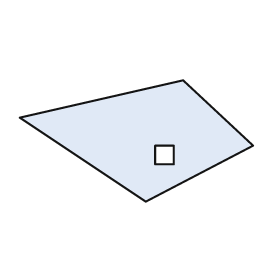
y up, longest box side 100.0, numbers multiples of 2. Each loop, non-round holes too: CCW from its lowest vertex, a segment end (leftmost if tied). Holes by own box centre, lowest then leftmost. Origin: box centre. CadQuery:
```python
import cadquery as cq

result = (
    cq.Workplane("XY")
    .moveTo(4.0, -26.0)
    .lineTo(50.0, -2.0)
    .lineTo(20.0, 26.0)
    .lineTo(-50.0, 10.0)
    .close()
    .moveTo(8.0, -10.0)
    .lineTo(16.0, -10.0)
    .lineTo(16.0, -2.0)
    .lineTo(8.0, -2.0)
    .close()
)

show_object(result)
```